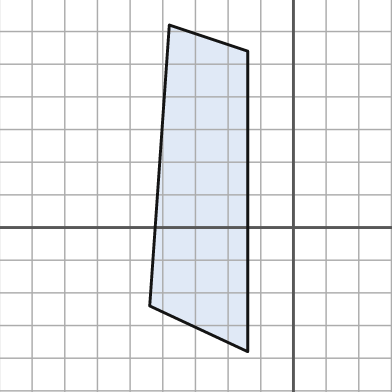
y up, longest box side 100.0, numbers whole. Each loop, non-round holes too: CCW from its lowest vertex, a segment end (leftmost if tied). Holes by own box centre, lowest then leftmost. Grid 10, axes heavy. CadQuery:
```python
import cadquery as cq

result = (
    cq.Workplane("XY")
    .moveTo(-14.0, -38.0)
    .lineTo(-14.0, 54.0)
    .lineTo(-38.0, 62.0)
    .lineTo(-44.0, -24.0)
    .close()
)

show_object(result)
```